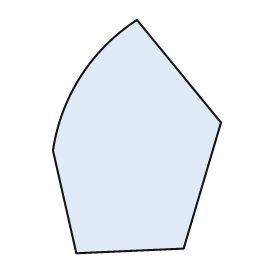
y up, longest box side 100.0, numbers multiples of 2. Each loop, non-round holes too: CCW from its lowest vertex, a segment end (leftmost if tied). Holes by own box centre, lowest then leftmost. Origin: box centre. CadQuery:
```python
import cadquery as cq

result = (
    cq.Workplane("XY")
    .moveTo(-26.0, -50.0)
    .lineTo(20.0, -48.0)
    .lineTo(36.0, 6.0)
    .lineTo(0.0, 50.0)
    .threePointArc((-24.0, 26.0), (-36.0, -6.0))
    .close()
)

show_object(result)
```